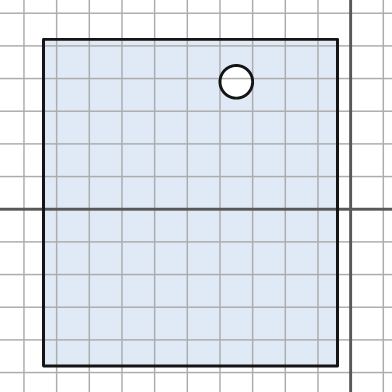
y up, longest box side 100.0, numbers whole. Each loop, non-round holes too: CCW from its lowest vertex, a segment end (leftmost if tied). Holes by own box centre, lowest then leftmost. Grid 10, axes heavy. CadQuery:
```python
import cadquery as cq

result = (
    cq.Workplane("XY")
    .moveTo(-94.0, -48.0)
    .lineTo(-4.0, -48.0)
    .lineTo(-4.0, 52.0)
    .lineTo(-94.0, 52.0)
    .close()
    .moveTo(-35.0, 39.0)
    .circle(5.0)
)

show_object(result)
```